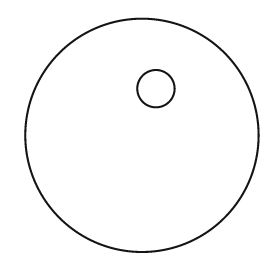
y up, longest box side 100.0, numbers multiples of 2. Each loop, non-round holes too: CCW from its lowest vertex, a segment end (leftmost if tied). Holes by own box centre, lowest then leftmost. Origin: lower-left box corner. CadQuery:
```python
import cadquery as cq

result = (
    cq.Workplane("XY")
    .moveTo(50.0, 50.0)
    .circle(50.0)
    .moveTo(56.0, 70.0)
    .circle(8.0)
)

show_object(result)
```